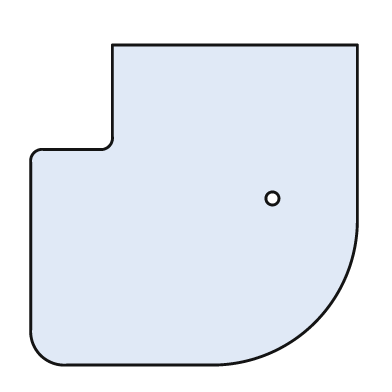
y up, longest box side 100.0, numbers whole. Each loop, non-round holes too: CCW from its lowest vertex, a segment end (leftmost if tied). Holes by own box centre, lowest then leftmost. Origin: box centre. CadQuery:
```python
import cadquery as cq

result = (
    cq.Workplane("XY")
    .moveTo(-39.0, -49.0)
    .lineTo(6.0, -49.0)
    .threePointArc((37.0, -36.0), (50.0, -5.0))
    .lineTo(50.0, 49.0)
    .lineTo(-25.0, 49.0)
    .lineTo(-25.0, 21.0)
    .threePointArc((-26.0, 18.0), (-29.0, 17.0))
    .lineTo(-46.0, 17.0)
    .threePointArc((-49.0, 16.0), (-50.0, 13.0))
    .lineTo(-50.0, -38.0)
    .threePointArc((-47.0, -46.0), (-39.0, -49.0))
    .close()
    .moveTo(24.0, 2.0)
    .circle(2.0)
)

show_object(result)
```